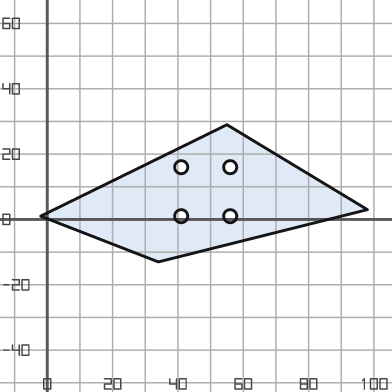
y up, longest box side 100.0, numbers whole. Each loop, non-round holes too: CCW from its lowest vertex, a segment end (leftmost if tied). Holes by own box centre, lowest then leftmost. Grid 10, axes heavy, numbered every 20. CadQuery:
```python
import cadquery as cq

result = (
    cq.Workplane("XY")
    .moveTo(34.0, -13.0)
    .lineTo(98.0, 3.0)
    .lineTo(55.0, 29.0)
    .lineTo(-2.0, 1.0)
    .close()
    .moveTo(41.0, 1.0)
    .circle(2.0)
    .moveTo(56.0, 1.0)
    .circle(2.0)
    .moveTo(41.0, 16.0)
    .circle(2.0)
    .moveTo(56.0, 16.0)
    .circle(2.0)
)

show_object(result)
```